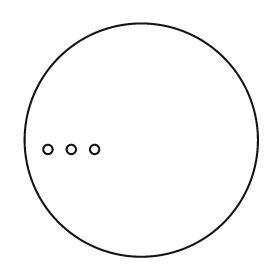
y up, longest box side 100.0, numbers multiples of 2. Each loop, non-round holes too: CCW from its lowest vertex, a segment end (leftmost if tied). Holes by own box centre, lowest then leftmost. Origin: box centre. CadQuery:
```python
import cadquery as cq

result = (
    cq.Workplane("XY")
    .moveTo(0.0, 0.0)
    .circle(50.0)
    .moveTo(-40.0, -4.0)
    .circle(2.0)
    .moveTo(-30.0, -4.0)
    .circle(2.0)
    .moveTo(-20.0, -4.0)
    .circle(2.0)
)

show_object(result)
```